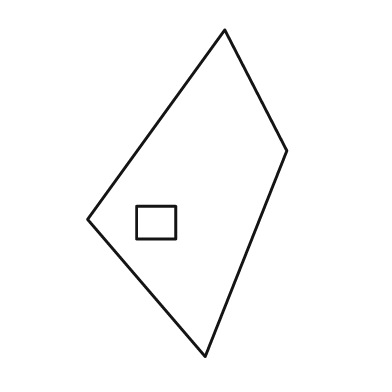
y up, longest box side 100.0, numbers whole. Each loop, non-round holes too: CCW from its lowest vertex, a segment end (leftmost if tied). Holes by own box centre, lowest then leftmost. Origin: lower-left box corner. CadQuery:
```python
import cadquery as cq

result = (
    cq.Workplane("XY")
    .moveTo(36.0, 0.0)
    .lineTo(61.0, 63.0)
    .lineTo(42.0, 100.0)
    .lineTo(0.0, 42.0)
    .close()
    .moveTo(15.0, 36.0)
    .lineTo(27.0, 36.0)
    .lineTo(27.0, 46.0)
    .lineTo(15.0, 46.0)
    .close()
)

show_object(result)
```